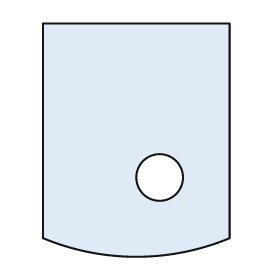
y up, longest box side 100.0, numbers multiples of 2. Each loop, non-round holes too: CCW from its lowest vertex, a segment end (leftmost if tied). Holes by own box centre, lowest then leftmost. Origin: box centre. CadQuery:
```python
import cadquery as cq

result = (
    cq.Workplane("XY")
    .moveTo(-40.0, -42.0)
    .threePointArc((0.0, -50.0), (40.0, -42.0))
    .lineTo(40.0, 50.0)
    .lineTo(-40.0, 50.0)
    .close()
    .moveTo(10.0, -16.0)
    .circle(10.0)
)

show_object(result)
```